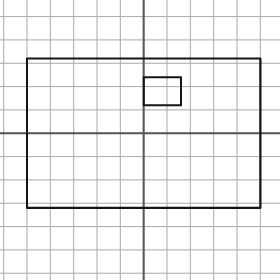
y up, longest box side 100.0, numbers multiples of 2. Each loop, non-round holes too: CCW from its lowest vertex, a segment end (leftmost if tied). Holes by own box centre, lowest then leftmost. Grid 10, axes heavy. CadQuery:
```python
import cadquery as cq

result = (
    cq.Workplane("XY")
    .moveTo(-50.0, -32.0)
    .lineTo(50.0, -32.0)
    .lineTo(50.0, 32.0)
    .lineTo(-50.0, 32.0)
    .close()
    .moveTo(0.0, 12.0)
    .lineTo(16.0, 12.0)
    .lineTo(16.0, 24.0)
    .lineTo(0.0, 24.0)
    .close()
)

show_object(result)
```